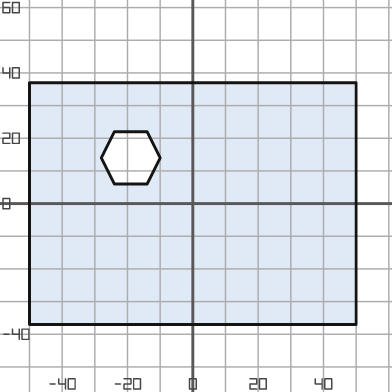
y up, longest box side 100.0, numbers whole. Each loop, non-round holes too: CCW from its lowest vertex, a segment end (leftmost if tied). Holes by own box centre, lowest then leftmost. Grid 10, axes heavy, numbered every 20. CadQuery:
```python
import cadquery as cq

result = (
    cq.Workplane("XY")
    .moveTo(-50.0, -37.0)
    .lineTo(50.0, -37.0)
    .lineTo(50.0, 37.0)
    .lineTo(-50.0, 37.0)
    .close()
    .moveTo(-24.0, 6.0)
    .lineTo(-14.0, 6.0)
    .lineTo(-10.0, 14.0)
    .lineTo(-14.0, 22.0)
    .lineTo(-24.0, 22.0)
    .lineTo(-28.0, 14.0)
    .close()
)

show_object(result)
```